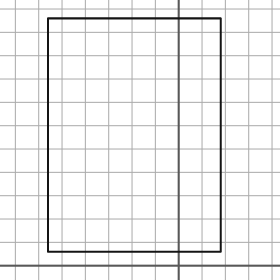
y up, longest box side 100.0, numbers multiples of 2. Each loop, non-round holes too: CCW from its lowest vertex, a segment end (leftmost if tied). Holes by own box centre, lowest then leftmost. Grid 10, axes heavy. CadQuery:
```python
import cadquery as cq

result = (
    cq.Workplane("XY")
    .moveTo(-56.0, 6.0)
    .lineTo(18.0, 6.0)
    .lineTo(18.0, 106.0)
    .lineTo(-56.0, 106.0)
    .close()
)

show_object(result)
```